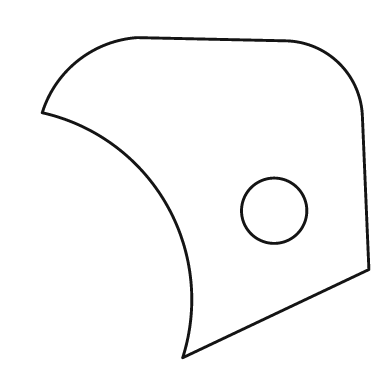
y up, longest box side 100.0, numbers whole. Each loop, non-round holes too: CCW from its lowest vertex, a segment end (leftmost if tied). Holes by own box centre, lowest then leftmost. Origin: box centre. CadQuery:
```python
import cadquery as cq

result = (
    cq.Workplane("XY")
    .moveTo(-7.0, -49.0)
    .lineTo(50.0, -22.0)
    .lineTo(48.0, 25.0)
    .threePointArc((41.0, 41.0), (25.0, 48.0))
    .lineTo(-21.0, 49.0)
    .threePointArc((-39.0, 42.0), (-50.0, 26.0))
    .threePointArc((-12.0, -2.0), (-7.0, -49.0))
    .close()
    .moveTo(21.0, -4.0)
    .circle(10.0)
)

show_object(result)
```